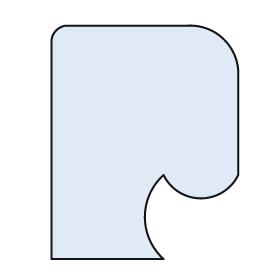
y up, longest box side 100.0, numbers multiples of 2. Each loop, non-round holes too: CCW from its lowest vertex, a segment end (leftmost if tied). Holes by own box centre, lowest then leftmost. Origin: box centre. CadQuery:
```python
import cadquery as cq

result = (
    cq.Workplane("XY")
    .moveTo(-40.0, -50.0)
    .lineTo(8.0, -50.0)
    .threePointArc((0.0, -32.0), (8.0, -14.0))
    .threePointArc((24.0, -24.0), (40.0, -14.0))
    .lineTo(40.0, 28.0)
    .threePointArc((34.0, 44.0), (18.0, 50.0))
    .lineTo(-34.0, 50.0)
    .threePointArc((-38.0, 48.0), (-40.0, 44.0))
    .close()
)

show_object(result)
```